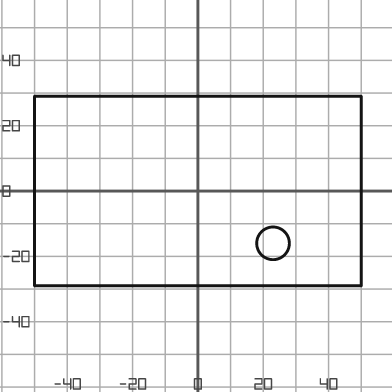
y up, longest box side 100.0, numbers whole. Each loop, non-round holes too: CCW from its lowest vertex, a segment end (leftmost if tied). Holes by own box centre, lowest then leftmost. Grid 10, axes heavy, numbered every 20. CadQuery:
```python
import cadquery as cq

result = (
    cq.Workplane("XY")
    .moveTo(-50.0, -29.0)
    .lineTo(50.0, -29.0)
    .lineTo(50.0, 29.0)
    .lineTo(-50.0, 29.0)
    .close()
    .moveTo(23.0, -16.0)
    .circle(5.0)
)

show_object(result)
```